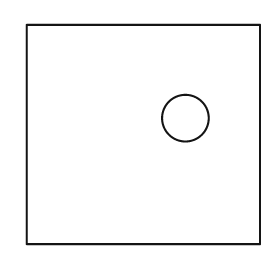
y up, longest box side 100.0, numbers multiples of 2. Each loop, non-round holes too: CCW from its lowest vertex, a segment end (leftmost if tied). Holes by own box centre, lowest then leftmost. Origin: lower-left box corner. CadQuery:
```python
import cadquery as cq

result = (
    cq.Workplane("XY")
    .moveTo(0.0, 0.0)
    .lineTo(100.0, 0.0)
    .lineTo(100.0, 94.0)
    .lineTo(0.0, 94.0)
    .close()
    .moveTo(68.0, 54.0)
    .circle(10.0)
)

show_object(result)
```